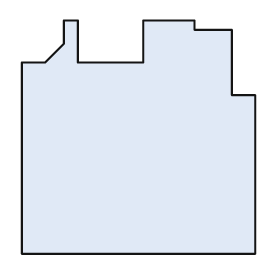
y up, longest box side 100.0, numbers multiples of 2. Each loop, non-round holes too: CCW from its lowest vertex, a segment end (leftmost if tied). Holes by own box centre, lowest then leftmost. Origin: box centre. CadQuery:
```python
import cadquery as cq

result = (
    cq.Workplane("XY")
    .moveTo(-50.0, -50.0)
    .lineTo(50.0, -50.0)
    .lineTo(50.0, 18.0)
    .lineTo(40.0, 18.0)
    .lineTo(40.0, 46.0)
    .lineTo(24.0, 46.0)
    .lineTo(24.0, 50.0)
    .lineTo(2.0, 50.0)
    .lineTo(2.0, 32.0)
    .lineTo(-26.0, 32.0)
    .lineTo(-26.0, 50.0)
    .lineTo(-32.0, 50.0)
    .lineTo(-32.0, 40.0)
    .lineTo(-40.0, 32.0)
    .lineTo(-50.0, 32.0)
    .close()
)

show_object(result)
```